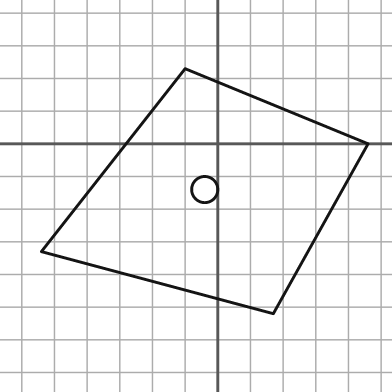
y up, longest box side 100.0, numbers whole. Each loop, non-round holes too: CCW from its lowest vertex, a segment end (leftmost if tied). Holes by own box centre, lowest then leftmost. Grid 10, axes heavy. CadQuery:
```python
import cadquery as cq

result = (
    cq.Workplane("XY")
    .moveTo(17.0, -52.0)
    .lineTo(46.0, 0.0)
    .lineTo(-10.0, 23.0)
    .lineTo(-54.0, -33.0)
    .close()
    .moveTo(-4.0, -14.0)
    .circle(4.0)
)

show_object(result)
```